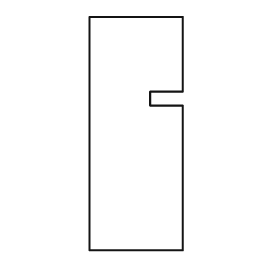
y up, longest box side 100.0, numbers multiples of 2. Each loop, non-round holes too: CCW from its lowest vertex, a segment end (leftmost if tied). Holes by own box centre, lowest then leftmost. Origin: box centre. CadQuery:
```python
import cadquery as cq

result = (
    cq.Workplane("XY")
    .moveTo(-20.0, -50.0)
    .lineTo(20.0, -50.0)
    .lineTo(20.0, 12.0)
    .lineTo(6.0, 12.0)
    .lineTo(6.0, 18.0)
    .lineTo(20.0, 18.0)
    .lineTo(20.0, 50.0)
    .lineTo(-20.0, 50.0)
    .close()
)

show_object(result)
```